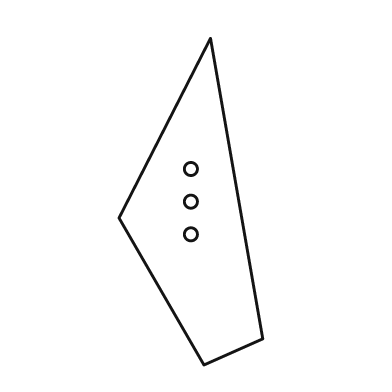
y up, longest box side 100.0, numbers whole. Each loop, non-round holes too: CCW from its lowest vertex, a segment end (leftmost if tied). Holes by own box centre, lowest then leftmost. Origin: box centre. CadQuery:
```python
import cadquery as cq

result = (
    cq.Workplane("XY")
    .moveTo(4.0, -50.0)
    .lineTo(22.0, -42.0)
    .lineTo(6.0, 50.0)
    .lineTo(-22.0, -5.0)
    .close()
    .moveTo(0.0, -10.0)
    .circle(2.0)
    .moveTo(0.0, 0.0)
    .circle(2.0)
    .moveTo(0.0, 10.0)
    .circle(2.0)
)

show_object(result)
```